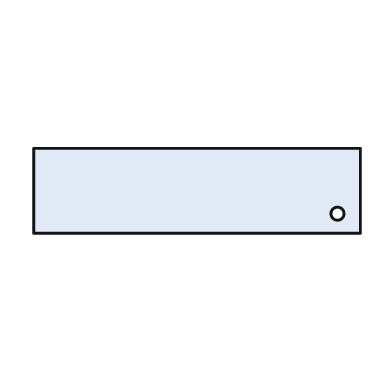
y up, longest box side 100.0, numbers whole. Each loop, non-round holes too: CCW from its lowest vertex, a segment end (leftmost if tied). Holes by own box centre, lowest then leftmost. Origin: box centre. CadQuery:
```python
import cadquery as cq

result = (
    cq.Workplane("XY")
    .moveTo(-50.0, -13.0)
    .lineTo(50.0, -13.0)
    .lineTo(50.0, 13.0)
    .lineTo(-50.0, 13.0)
    .close()
    .moveTo(43.0, -7.0)
    .circle(2.0)
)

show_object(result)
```